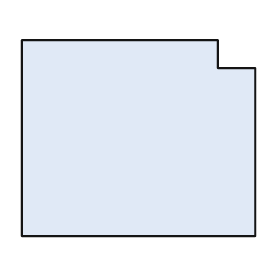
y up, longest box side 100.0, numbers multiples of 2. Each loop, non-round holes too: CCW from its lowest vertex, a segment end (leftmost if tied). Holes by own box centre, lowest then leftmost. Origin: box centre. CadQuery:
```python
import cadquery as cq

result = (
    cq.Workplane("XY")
    .moveTo(-50.0, -42.0)
    .lineTo(50.0, -42.0)
    .lineTo(50.0, 30.0)
    .lineTo(34.0, 30.0)
    .lineTo(34.0, 42.0)
    .lineTo(-50.0, 42.0)
    .close()
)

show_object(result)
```